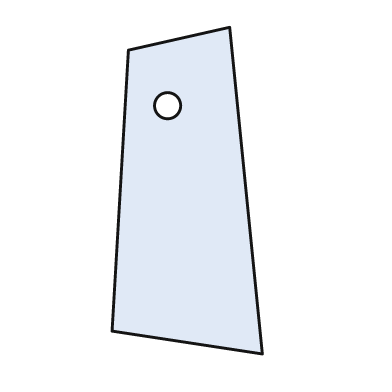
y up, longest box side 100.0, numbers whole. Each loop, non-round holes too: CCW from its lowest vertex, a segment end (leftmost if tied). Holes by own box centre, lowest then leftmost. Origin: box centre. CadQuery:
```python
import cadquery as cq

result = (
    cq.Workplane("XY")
    .moveTo(23.0, -50.0)
    .lineTo(13.0, 50.0)
    .lineTo(-18.0, 43.0)
    .lineTo(-23.0, -43.0)
    .close()
    .moveTo(-6.0, 26.0)
    .circle(4.0)
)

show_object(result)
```